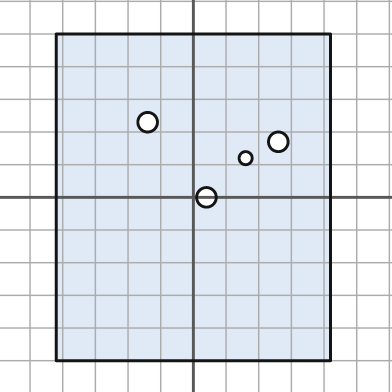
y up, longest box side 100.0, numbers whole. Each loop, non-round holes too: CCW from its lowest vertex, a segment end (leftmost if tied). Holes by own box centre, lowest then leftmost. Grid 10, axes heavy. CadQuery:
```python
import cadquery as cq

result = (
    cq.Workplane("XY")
    .moveTo(-42.0, -50.0)
    .lineTo(42.0, -50.0)
    .lineTo(42.0, 50.0)
    .lineTo(-42.0, 50.0)
    .close()
    .moveTo(4.0, 0.0)
    .circle(3.0)
    .moveTo(16.0, 12.0)
    .circle(2.0)
    .moveTo(26.0, 17.0)
    .circle(3.0)
    .moveTo(-14.0, 23.0)
    .circle(3.0)
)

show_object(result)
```